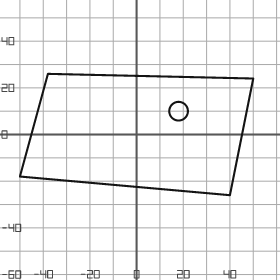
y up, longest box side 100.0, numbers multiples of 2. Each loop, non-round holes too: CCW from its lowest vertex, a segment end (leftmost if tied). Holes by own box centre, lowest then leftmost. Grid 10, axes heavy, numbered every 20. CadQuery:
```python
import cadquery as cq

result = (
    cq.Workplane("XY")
    .moveTo(40.0, -26.0)
    .lineTo(50.0, 24.0)
    .lineTo(-38.0, 26.0)
    .lineTo(-50.0, -18.0)
    .close()
    .moveTo(18.0, 10.0)
    .circle(4.0)
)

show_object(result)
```